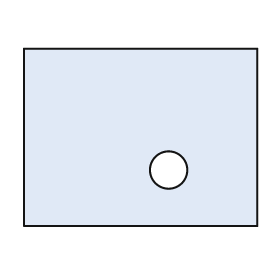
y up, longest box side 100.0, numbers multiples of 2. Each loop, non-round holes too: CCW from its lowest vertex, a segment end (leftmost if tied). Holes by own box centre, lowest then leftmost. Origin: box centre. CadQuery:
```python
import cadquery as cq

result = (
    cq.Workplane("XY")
    .moveTo(-50.0, -38.0)
    .lineTo(50.0, -38.0)
    .lineTo(50.0, 38.0)
    .lineTo(-50.0, 38.0)
    .close()
    .moveTo(12.0, -14.0)
    .circle(8.0)
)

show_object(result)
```